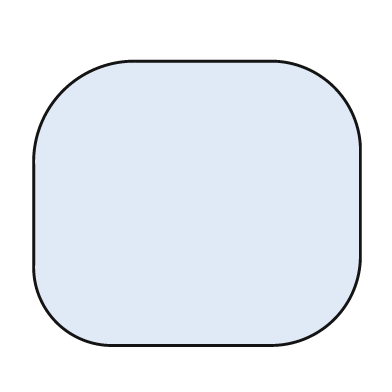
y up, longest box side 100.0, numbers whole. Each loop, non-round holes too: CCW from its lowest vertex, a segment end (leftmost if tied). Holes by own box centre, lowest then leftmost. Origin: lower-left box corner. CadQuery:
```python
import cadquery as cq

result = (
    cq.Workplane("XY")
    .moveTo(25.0, 0.0)
    .lineTo(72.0, 0.0)
    .threePointArc((92.0, 8.0), (100.0, 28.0))
    .lineTo(100.0, 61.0)
    .threePointArc((92.0, 79.0), (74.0, 87.0))
    .lineTo(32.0, 87.0)
    .threePointArc((9.0, 78.0), (0.0, 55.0))
    .lineTo(0.0, 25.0)
    .threePointArc((7.0, 7.0), (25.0, 0.0))
    .close()
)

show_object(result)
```